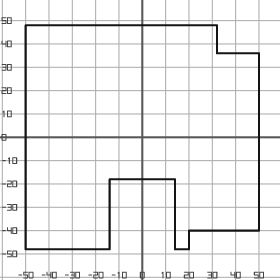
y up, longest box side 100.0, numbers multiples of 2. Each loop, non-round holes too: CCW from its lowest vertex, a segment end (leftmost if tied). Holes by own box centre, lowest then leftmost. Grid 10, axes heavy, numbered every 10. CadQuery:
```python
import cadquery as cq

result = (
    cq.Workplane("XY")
    .moveTo(-50.0, -48.0)
    .lineTo(-14.0, -48.0)
    .lineTo(-14.0, -18.0)
    .lineTo(14.0, -18.0)
    .lineTo(14.0, -48.0)
    .lineTo(20.0, -48.0)
    .lineTo(20.0, -40.0)
    .lineTo(50.0, -40.0)
    .lineTo(50.0, 36.0)
    .lineTo(32.0, 36.0)
    .lineTo(32.0, 48.0)
    .lineTo(-50.0, 48.0)
    .close()
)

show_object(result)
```